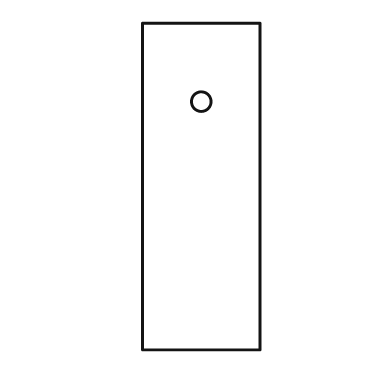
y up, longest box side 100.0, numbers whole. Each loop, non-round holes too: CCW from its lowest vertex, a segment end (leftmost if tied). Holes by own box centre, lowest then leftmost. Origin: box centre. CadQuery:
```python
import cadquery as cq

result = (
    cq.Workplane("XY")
    .moveTo(-18.0, -50.0)
    .lineTo(18.0, -50.0)
    .lineTo(18.0, 50.0)
    .lineTo(-18.0, 50.0)
    .close()
    .moveTo(0.0, 26.0)
    .circle(3.0)
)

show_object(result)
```